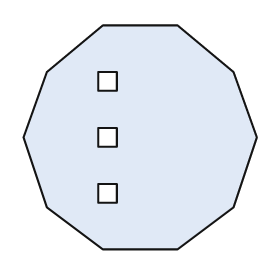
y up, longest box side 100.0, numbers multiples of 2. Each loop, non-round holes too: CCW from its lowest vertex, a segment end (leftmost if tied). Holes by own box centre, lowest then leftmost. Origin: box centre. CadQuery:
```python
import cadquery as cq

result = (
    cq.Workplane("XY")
    .moveTo(-16.0, -48.0)
    .lineTo(16.0, -48.0)
    .lineTo(40.0, -30.0)
    .lineTo(50.0, 0.0)
    .lineTo(40.0, 28.0)
    .lineTo(16.0, 48.0)
    .lineTo(-16.0, 48.0)
    .lineTo(-40.0, 28.0)
    .lineTo(-50.0, 0.0)
    .lineTo(-40.0, -30.0)
    .close()
    .moveTo(-18.0, -28.0)
    .lineTo(-10.0, -28.0)
    .lineTo(-10.0, -20.0)
    .lineTo(-18.0, -20.0)
    .close()
    .moveTo(-18.0, -4.0)
    .lineTo(-10.0, -4.0)
    .lineTo(-10.0, 4.0)
    .lineTo(-18.0, 4.0)
    .close()
    .moveTo(-18.0, 20.0)
    .lineTo(-10.0, 20.0)
    .lineTo(-10.0, 28.0)
    .lineTo(-18.0, 28.0)
    .close()
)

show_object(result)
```